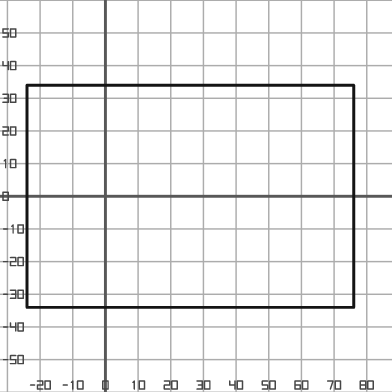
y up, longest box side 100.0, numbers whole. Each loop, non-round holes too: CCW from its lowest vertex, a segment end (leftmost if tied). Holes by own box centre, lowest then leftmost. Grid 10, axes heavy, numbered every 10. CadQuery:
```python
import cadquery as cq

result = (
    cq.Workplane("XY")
    .moveTo(-24.0, -34.0)
    .lineTo(76.0, -34.0)
    .lineTo(76.0, 34.0)
    .lineTo(-24.0, 34.0)
    .close()
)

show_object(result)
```